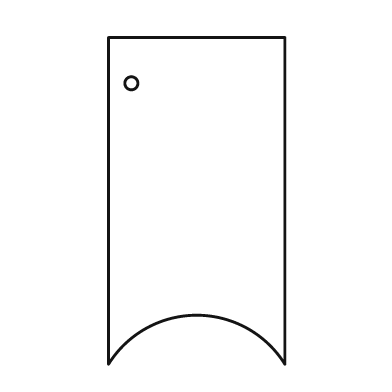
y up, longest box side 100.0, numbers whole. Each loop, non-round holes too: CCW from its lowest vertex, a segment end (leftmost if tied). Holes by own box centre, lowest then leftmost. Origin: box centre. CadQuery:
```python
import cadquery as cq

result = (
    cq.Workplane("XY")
    .moveTo(-27.0, -50.0)
    .threePointArc((0.0, -35.0), (27.0, -50.0))
    .lineTo(27.0, 50.0)
    .lineTo(-27.0, 50.0)
    .close()
    .moveTo(-20.0, 36.0)
    .circle(2.0)
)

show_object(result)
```